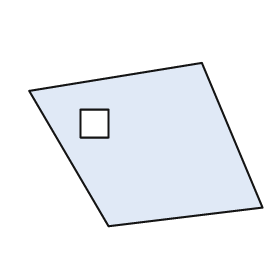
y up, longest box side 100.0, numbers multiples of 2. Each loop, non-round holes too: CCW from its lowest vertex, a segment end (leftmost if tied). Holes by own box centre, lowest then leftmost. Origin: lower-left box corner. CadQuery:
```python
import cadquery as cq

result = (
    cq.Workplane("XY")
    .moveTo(34.0, 0.0)
    .lineTo(100.0, 8.0)
    .lineTo(74.0, 70.0)
    .lineTo(0.0, 58.0)
    .close()
    .moveTo(22.0, 38.0)
    .lineTo(34.0, 38.0)
    .lineTo(34.0, 50.0)
    .lineTo(22.0, 50.0)
    .close()
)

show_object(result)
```